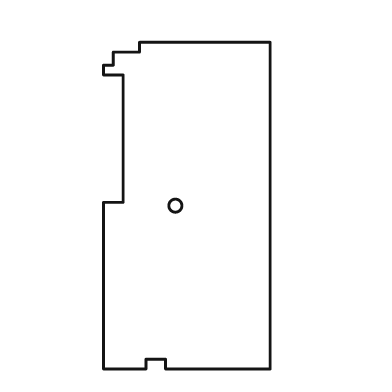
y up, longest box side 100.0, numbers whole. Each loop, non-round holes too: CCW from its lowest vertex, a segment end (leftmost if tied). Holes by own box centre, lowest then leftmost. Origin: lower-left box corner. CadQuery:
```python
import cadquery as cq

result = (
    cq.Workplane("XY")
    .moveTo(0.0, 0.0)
    .lineTo(13.0, 0.0)
    .lineTo(13.0, 3.0)
    .lineTo(19.0, 3.0)
    .lineTo(19.0, 0.0)
    .lineTo(51.0, 0.0)
    .lineTo(51.0, 100.0)
    .lineTo(11.0, 100.0)
    .lineTo(11.0, 97.0)
    .lineTo(3.0, 97.0)
    .lineTo(3.0, 93.0)
    .lineTo(0.0, 93.0)
    .lineTo(0.0, 90.0)
    .lineTo(6.0, 90.0)
    .lineTo(6.0, 51.0)
    .lineTo(0.0, 51.0)
    .close()
    .moveTo(22.0, 50.0)
    .circle(2.0)
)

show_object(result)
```